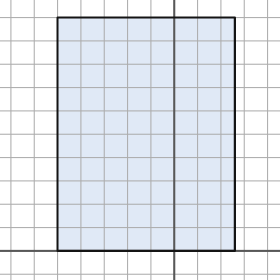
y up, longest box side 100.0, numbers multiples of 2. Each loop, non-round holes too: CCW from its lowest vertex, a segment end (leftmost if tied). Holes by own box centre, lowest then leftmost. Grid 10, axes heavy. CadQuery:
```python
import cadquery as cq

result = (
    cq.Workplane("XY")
    .moveTo(-50.0, 0.0)
    .lineTo(26.0, 0.0)
    .lineTo(26.0, 100.0)
    .lineTo(-50.0, 100.0)
    .close()
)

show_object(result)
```